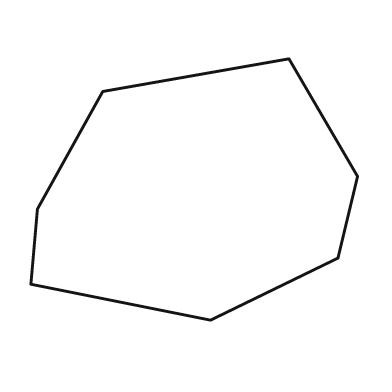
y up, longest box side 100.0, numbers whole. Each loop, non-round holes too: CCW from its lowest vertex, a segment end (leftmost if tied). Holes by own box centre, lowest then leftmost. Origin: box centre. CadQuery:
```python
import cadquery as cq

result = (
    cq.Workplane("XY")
    .moveTo(5.0, -40.0)
    .lineTo(44.0, -21.0)
    .lineTo(50.0, 4.0)
    .lineTo(29.0, 40.0)
    .lineTo(-28.0, 30.0)
    .lineTo(-48.0, -6.0)
    .lineTo(-50.0, -29.0)
    .close()
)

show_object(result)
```